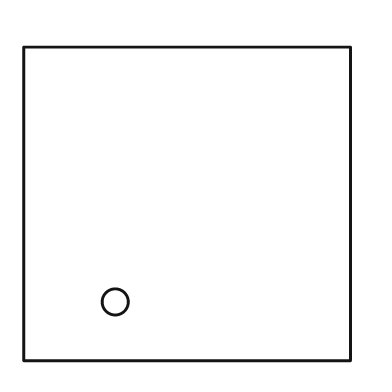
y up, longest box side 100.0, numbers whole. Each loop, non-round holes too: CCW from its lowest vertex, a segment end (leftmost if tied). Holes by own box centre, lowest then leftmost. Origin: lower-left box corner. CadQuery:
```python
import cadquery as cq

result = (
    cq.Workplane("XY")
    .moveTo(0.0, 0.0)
    .lineTo(100.0, 0.0)
    .lineTo(100.0, 96.0)
    .lineTo(0.0, 96.0)
    .close()
    .moveTo(28.0, 18.0)
    .circle(4.0)
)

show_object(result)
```